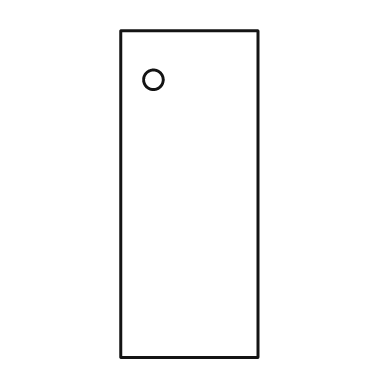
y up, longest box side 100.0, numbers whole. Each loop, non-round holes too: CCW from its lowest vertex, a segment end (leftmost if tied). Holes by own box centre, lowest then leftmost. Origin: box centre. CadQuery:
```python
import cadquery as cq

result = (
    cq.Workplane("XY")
    .moveTo(-21.0, -50.0)
    .lineTo(21.0, -50.0)
    .lineTo(21.0, 50.0)
    .lineTo(-21.0, 50.0)
    .close()
    .moveTo(-11.0, 35.0)
    .circle(3.0)
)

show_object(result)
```